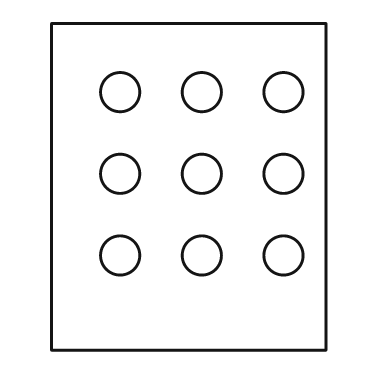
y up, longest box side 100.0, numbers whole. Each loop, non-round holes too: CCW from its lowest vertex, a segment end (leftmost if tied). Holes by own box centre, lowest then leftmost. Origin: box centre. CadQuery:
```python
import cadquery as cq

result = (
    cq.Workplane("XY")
    .moveTo(-42.0, -50.0)
    .lineTo(42.0, -50.0)
    .lineTo(42.0, 50.0)
    .lineTo(-42.0, 50.0)
    .close()
    .moveTo(-21.0, -21.0)
    .circle(6.0)
    .moveTo(4.0, -21.0)
    .circle(6.0)
    .moveTo(29.0, -21.0)
    .circle(6.0)
    .moveTo(-21.0, 4.0)
    .circle(6.0)
    .moveTo(4.0, 4.0)
    .circle(6.0)
    .moveTo(29.0, 4.0)
    .circle(6.0)
    .moveTo(-21.0, 29.0)
    .circle(6.0)
    .moveTo(4.0, 29.0)
    .circle(6.0)
    .moveTo(29.0, 29.0)
    .circle(6.0)
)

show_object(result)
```